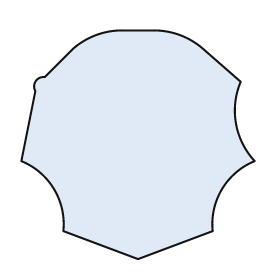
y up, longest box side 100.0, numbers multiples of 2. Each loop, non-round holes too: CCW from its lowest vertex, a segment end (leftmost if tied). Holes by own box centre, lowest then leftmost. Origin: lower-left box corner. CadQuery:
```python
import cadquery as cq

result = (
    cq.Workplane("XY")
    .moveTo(50.0, 0.0)
    .lineTo(82.0, 12.0)
    .threePointArc((86.0, 30.0), (100.0, 42.0))
    .threePointArc((92.0, 58.0), (94.0, 76.0))
    .lineTo(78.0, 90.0)
    .threePointArc((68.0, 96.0), (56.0, 98.0))
    .lineTo(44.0, 98.0)
    .threePointArc((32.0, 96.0), (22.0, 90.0))
    .lineTo(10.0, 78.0)
    .threePointArc((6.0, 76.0), (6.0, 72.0))
    .lineTo(0.0, 42.0)
    .threePointArc((14.0, 30.0), (18.0, 12.0))
    .close()
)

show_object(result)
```